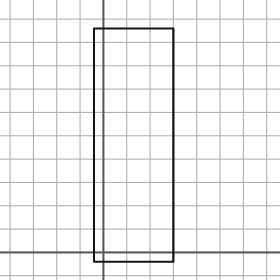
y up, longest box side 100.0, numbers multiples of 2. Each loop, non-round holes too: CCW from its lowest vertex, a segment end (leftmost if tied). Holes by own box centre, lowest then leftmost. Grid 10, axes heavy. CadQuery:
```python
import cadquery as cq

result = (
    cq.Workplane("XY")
    .moveTo(-4.0, -4.0)
    .lineTo(30.0, -4.0)
    .lineTo(30.0, 96.0)
    .lineTo(-4.0, 96.0)
    .close()
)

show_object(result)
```